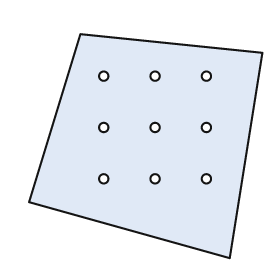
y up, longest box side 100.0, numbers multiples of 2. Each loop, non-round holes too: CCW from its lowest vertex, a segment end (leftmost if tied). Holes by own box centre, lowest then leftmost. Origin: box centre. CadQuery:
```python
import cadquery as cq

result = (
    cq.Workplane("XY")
    .moveTo(36.0, -48.0)
    .lineTo(50.0, 40.0)
    .lineTo(-28.0, 48.0)
    .lineTo(-50.0, -24.0)
    .close()
    .moveTo(-18.0, -14.0)
    .circle(2.0)
    .moveTo(4.0, -14.0)
    .circle(2.0)
    .moveTo(26.0, -14.0)
    .circle(2.0)
    .moveTo(-18.0, 8.0)
    .circle(2.0)
    .moveTo(4.0, 8.0)
    .circle(2.0)
    .moveTo(26.0, 8.0)
    .circle(2.0)
    .moveTo(-18.0, 30.0)
    .circle(2.0)
    .moveTo(4.0, 30.0)
    .circle(2.0)
    .moveTo(26.0, 30.0)
    .circle(2.0)
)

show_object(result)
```